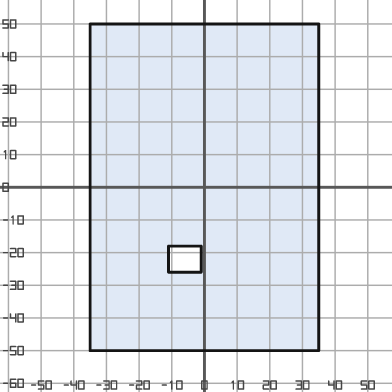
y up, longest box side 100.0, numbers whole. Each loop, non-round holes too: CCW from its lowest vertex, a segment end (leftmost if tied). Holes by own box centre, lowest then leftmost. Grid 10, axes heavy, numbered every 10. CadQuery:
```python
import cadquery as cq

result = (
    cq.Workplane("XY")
    .moveTo(-35.0, -50.0)
    .lineTo(35.0, -50.0)
    .lineTo(35.0, 50.0)
    .lineTo(-35.0, 50.0)
    .close()
    .moveTo(-11.0, -26.0)
    .lineTo(-1.0, -26.0)
    .lineTo(-1.0, -18.0)
    .lineTo(-11.0, -18.0)
    .close()
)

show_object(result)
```